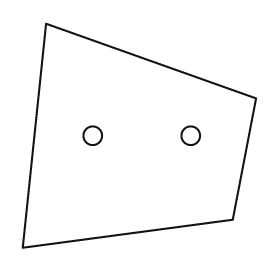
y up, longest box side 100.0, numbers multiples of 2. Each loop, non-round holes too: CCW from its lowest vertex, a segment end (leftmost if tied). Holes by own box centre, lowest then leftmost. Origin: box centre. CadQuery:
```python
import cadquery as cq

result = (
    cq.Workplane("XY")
    .moveTo(-50.0, -48.0)
    .lineTo(40.0, -36.0)
    .lineTo(50.0, 16.0)
    .lineTo(-40.0, 48.0)
    .close()
    .moveTo(-20.0, 0.0)
    .circle(4.0)
    .moveTo(22.0, 0.0)
    .circle(4.0)
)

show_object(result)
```